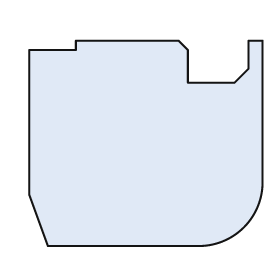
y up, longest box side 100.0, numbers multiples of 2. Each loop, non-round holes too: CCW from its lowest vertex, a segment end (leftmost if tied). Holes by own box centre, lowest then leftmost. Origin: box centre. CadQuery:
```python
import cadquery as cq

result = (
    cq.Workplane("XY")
    .moveTo(-42.0, -44.0)
    .lineTo(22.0, -44.0)
    .threePointArc((42.0, -36.0), (50.0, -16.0))
    .lineTo(50.0, 44.0)
    .lineTo(44.0, 44.0)
    .lineTo(44.0, 32.0)
    .lineTo(38.0, 26.0)
    .lineTo(18.0, 26.0)
    .lineTo(18.0, 40.0)
    .lineTo(14.0, 44.0)
    .lineTo(-30.0, 44.0)
    .lineTo(-30.0, 40.0)
    .lineTo(-50.0, 40.0)
    .lineTo(-50.0, -22.0)
    .close()
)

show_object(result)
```